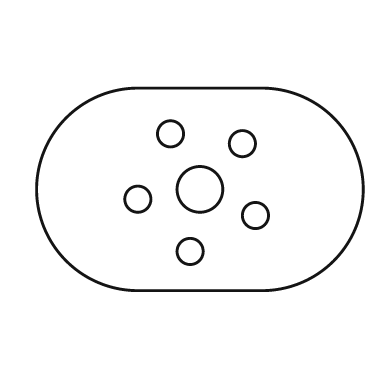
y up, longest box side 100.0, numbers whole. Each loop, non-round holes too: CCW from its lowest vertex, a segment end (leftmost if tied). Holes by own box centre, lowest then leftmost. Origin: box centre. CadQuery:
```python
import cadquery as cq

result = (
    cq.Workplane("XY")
    .moveTo(-19.0, -31.0)
    .lineTo(19.0, -31.0)
    .threePointArc((50.0, 0.0), (19.0, 31.0))
    .lineTo(-19.0, 31.0)
    .threePointArc((-50.0, 0.0), (-19.0, -31.0))
    .close()
    .moveTo(-3.0, -19.0)
    .circle(4.0)
    .moveTo(17.0, -8.0)
    .circle(4.0)
    .moveTo(-19.0, -3.0)
    .circle(4.0)
    .moveTo(0.0, 0.0)
    .circle(7.0)
    .moveTo(13.0, 14.0)
    .circle(4.0)
    .moveTo(-9.0, 17.0)
    .circle(4.0)
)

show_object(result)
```